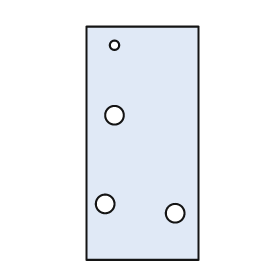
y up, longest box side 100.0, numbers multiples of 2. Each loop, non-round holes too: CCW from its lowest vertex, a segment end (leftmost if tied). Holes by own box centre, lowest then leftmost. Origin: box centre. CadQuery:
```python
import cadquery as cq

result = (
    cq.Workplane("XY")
    .moveTo(-24.0, -50.0)
    .lineTo(24.0, -50.0)
    .lineTo(24.0, 50.0)
    .lineTo(-24.0, 50.0)
    .close()
    .moveTo(14.0, -30.0)
    .circle(4.0)
    .moveTo(-16.0, -26.0)
    .circle(4.0)
    .moveTo(-12.0, 12.0)
    .circle(4.0)
    .moveTo(-12.0, 42.0)
    .circle(2.0)
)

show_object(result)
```